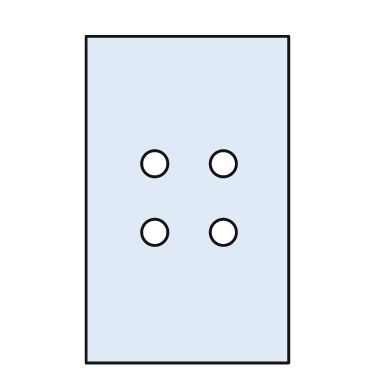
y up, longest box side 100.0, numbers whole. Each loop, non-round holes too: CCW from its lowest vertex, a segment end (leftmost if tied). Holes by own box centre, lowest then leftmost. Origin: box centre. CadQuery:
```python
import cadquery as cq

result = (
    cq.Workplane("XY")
    .moveTo(-31.0, -50.0)
    .lineTo(31.0, -50.0)
    .lineTo(31.0, 50.0)
    .lineTo(-31.0, 50.0)
    .close()
    .moveTo(-10.0, -10.0)
    .circle(4.0)
    .moveTo(11.0, -10.0)
    .circle(4.0)
    .moveTo(-10.0, 11.0)
    .circle(4.0)
    .moveTo(11.0, 11.0)
    .circle(4.0)
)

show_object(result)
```